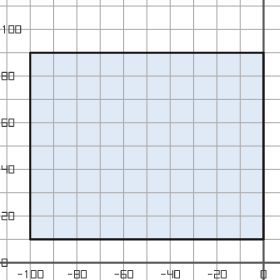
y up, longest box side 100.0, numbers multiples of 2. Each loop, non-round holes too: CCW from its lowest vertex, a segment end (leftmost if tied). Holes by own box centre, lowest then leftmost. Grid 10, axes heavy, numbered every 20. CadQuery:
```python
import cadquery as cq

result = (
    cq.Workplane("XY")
    .moveTo(-100.0, 10.0)
    .lineTo(0.0, 10.0)
    .lineTo(0.0, 90.0)
    .lineTo(-100.0, 90.0)
    .close()
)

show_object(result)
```